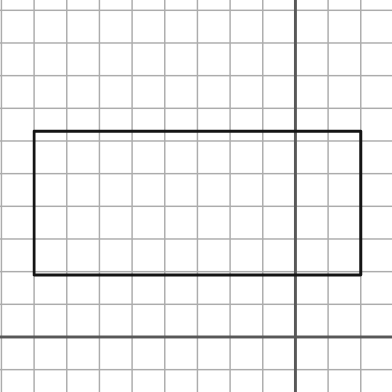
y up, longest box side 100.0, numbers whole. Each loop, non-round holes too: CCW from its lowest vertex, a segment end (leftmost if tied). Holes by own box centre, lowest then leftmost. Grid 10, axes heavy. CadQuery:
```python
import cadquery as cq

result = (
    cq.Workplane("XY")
    .moveTo(-80.0, 19.0)
    .lineTo(20.0, 19.0)
    .lineTo(20.0, 63.0)
    .lineTo(-80.0, 63.0)
    .close()
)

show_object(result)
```